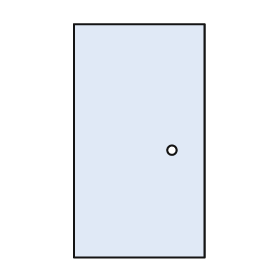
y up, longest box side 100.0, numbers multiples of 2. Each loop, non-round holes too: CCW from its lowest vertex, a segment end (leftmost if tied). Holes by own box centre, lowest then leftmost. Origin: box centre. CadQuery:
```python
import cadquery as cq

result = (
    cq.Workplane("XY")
    .moveTo(-28.0, -50.0)
    .lineTo(28.0, -50.0)
    .lineTo(28.0, 50.0)
    .lineTo(-28.0, 50.0)
    .close()
    .moveTo(14.0, -4.0)
    .circle(2.0)
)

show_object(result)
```